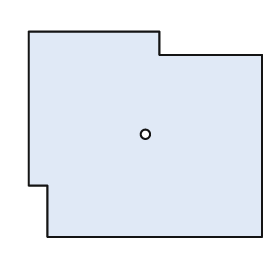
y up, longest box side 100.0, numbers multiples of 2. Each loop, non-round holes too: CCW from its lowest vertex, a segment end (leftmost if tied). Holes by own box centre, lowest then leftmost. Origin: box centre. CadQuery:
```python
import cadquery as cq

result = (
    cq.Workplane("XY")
    .moveTo(-42.0, -44.0)
    .lineTo(50.0, -44.0)
    .lineTo(50.0, 34.0)
    .lineTo(6.0, 34.0)
    .lineTo(6.0, 44.0)
    .lineTo(-50.0, 44.0)
    .lineTo(-50.0, -22.0)
    .lineTo(-42.0, -22.0)
    .close()
    .moveTo(0.0, 0.0)
    .circle(2.0)
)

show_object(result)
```